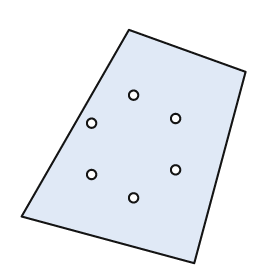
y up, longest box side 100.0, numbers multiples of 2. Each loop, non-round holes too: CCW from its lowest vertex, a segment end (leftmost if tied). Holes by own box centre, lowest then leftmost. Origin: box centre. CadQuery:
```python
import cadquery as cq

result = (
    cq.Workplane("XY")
    .moveTo(26.0, -50.0)
    .lineTo(48.0, 32.0)
    .lineTo(-2.0, 50.0)
    .lineTo(-48.0, -30.0)
    .close()
    .moveTo(0.0, -22.0)
    .circle(2.0)
    .moveTo(-18.0, -12.0)
    .circle(2.0)
    .moveTo(18.0, -10.0)
    .circle(2.0)
    .moveTo(-18.0, 10.0)
    .circle(2.0)
    .moveTo(18.0, 12.0)
    .circle(2.0)
    .moveTo(0.0, 22.0)
    .circle(2.0)
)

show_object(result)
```